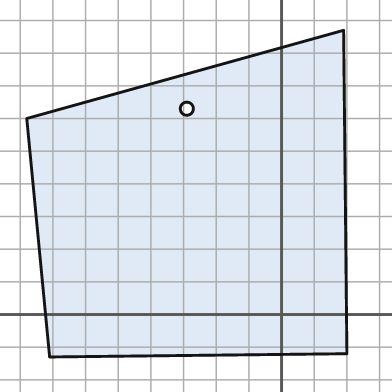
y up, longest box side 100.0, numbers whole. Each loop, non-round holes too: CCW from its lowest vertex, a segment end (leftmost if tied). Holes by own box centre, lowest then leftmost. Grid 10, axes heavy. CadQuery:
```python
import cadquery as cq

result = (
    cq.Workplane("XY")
    .moveTo(-71.0, -13.0)
    .lineTo(20.0, -12.0)
    .lineTo(19.0, 87.0)
    .lineTo(-78.0, 60.0)
    .close()
    .moveTo(-29.0, 63.0)
    .circle(2.0)
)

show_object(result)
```